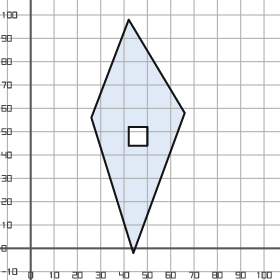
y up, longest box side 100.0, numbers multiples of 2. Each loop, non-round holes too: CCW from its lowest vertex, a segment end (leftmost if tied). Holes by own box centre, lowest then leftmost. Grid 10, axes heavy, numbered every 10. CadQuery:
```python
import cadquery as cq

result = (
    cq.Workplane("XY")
    .moveTo(44.0, -2.0)
    .lineTo(66.0, 58.0)
    .lineTo(42.0, 98.0)
    .lineTo(26.0, 56.0)
    .close()
    .moveTo(42.0, 44.0)
    .lineTo(50.0, 44.0)
    .lineTo(50.0, 52.0)
    .lineTo(42.0, 52.0)
    .close()
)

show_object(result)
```